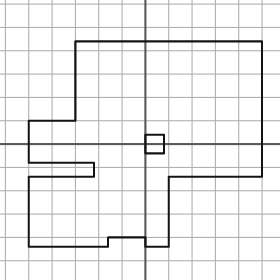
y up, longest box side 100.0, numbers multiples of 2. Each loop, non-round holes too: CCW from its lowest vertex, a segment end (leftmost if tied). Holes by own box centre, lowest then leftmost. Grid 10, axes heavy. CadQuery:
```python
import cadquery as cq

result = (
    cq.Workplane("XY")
    .moveTo(-50.0, -44.0)
    .lineTo(-16.0, -44.0)
    .lineTo(-16.0, -40.0)
    .lineTo(0.0, -40.0)
    .lineTo(0.0, -44.0)
    .lineTo(10.0, -44.0)
    .lineTo(10.0, -14.0)
    .lineTo(50.0, -14.0)
    .lineTo(50.0, 44.0)
    .lineTo(-30.0, 44.0)
    .lineTo(-30.0, 10.0)
    .lineTo(-50.0, 10.0)
    .lineTo(-50.0, -8.0)
    .lineTo(-22.0, -8.0)
    .lineTo(-22.0, -14.0)
    .lineTo(-50.0, -14.0)
    .close()
    .moveTo(0.0, -4.0)
    .lineTo(8.0, -4.0)
    .lineTo(8.0, 4.0)
    .lineTo(0.0, 4.0)
    .close()
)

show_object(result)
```